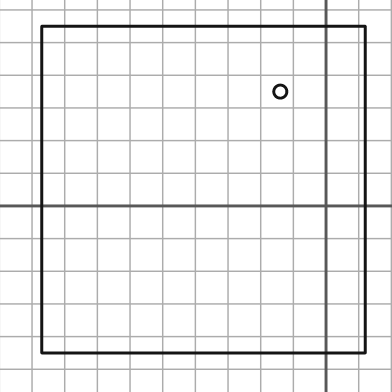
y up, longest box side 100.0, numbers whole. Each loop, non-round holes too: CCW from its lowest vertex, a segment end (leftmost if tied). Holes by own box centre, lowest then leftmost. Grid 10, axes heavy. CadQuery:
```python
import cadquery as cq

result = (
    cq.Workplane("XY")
    .moveTo(-87.0, -45.0)
    .lineTo(12.0, -45.0)
    .lineTo(12.0, 55.0)
    .lineTo(-87.0, 55.0)
    .close()
    .moveTo(-14.0, 35.0)
    .circle(2.0)
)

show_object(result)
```